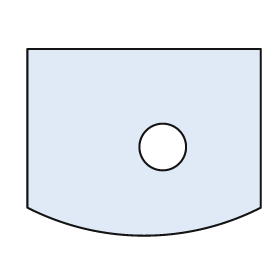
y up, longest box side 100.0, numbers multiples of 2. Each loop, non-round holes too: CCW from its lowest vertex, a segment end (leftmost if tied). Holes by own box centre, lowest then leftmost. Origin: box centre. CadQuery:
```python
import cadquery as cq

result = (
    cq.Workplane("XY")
    .moveTo(-50.0, -28.0)
    .threePointArc((0.0, -40.0), (50.0, -28.0))
    .lineTo(50.0, 40.0)
    .lineTo(-50.0, 40.0)
    .close()
    .moveTo(8.0, -2.0)
    .circle(10.0)
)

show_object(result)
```